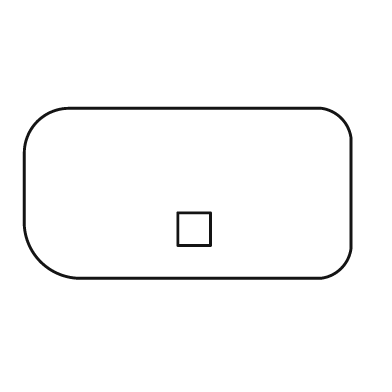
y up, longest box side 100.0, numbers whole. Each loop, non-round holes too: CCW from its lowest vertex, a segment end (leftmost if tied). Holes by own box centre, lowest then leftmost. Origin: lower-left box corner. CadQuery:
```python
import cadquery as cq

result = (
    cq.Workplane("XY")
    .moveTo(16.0, 0.0)
    .lineTo(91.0, 0.0)
    .threePointArc((97.0, 3.0), (100.0, 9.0))
    .lineTo(100.0, 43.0)
    .threePointArc((97.0, 49.0), (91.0, 52.0))
    .lineTo(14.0, 52.0)
    .threePointArc((4.0, 48.0), (0.0, 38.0))
    .lineTo(0.0, 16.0)
    .threePointArc((5.0, 5.0), (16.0, 0.0))
    .close()
    .moveTo(47.0, 10.0)
    .lineTo(57.0, 10.0)
    .lineTo(57.0, 20.0)
    .lineTo(47.0, 20.0)
    .close()
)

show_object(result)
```